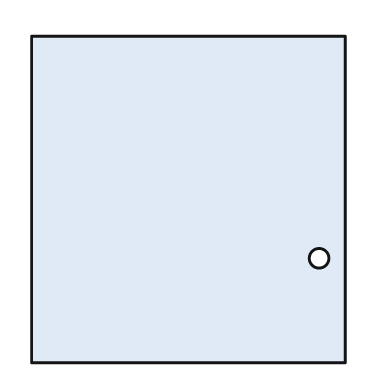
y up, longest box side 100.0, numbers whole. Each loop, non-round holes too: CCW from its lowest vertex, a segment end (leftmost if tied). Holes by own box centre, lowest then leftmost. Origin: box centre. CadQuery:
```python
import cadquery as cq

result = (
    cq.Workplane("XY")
    .moveTo(-48.0, -50.0)
    .lineTo(48.0, -50.0)
    .lineTo(48.0, 50.0)
    .lineTo(-48.0, 50.0)
    .close()
    .moveTo(40.0, -18.0)
    .circle(3.0)
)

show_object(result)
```